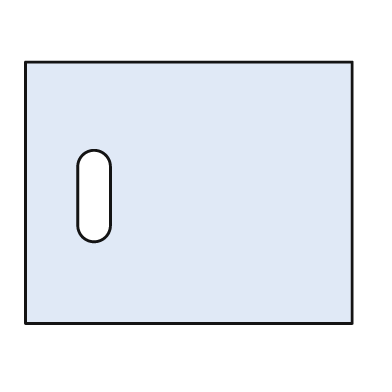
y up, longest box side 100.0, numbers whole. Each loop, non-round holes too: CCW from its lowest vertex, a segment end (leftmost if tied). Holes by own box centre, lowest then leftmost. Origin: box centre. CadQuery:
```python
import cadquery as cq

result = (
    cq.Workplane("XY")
    .moveTo(-50.0, -40.0)
    .lineTo(50.0, -40.0)
    .lineTo(50.0, 40.0)
    .lineTo(-50.0, 40.0)
    .close()
    .moveTo(-34.0, -10.0)
    .threePointArc((-29.0, -15.0), (-24.0, -10.0))
    .lineTo(-24.0, 8.0)
    .threePointArc((-29.0, 13.0), (-34.0, 8.0))
    .close()
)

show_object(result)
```